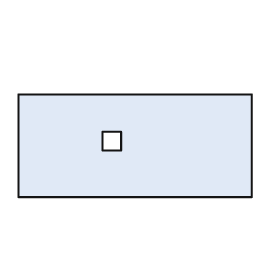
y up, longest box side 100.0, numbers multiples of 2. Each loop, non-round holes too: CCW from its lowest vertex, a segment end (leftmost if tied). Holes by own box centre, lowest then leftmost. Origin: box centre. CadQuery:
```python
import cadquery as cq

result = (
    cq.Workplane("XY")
    .moveTo(-50.0, -22.0)
    .lineTo(50.0, -22.0)
    .lineTo(50.0, 22.0)
    .lineTo(-50.0, 22.0)
    .close()
    .moveTo(-14.0, -2.0)
    .lineTo(-6.0, -2.0)
    .lineTo(-6.0, 6.0)
    .lineTo(-14.0, 6.0)
    .close()
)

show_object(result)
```